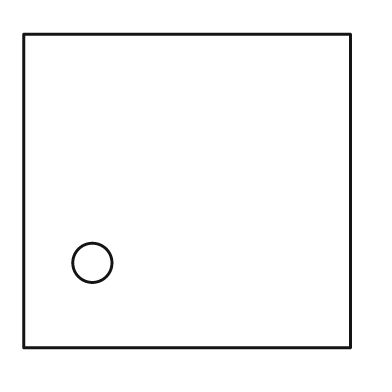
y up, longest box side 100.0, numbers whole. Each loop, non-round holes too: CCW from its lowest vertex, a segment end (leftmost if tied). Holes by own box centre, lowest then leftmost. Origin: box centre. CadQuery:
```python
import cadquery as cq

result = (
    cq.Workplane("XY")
    .moveTo(-50.0, -48.0)
    .lineTo(50.0, -48.0)
    .lineTo(50.0, 48.0)
    .lineTo(-50.0, 48.0)
    .close()
    .moveTo(-29.0, -22.0)
    .circle(6.0)
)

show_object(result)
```